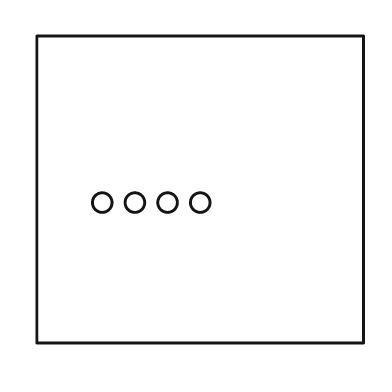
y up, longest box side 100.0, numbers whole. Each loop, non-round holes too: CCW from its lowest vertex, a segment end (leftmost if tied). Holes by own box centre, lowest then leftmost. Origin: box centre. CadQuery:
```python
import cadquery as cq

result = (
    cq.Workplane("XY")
    .moveTo(-50.0, -47.0)
    .lineTo(50.0, -47.0)
    .lineTo(50.0, 47.0)
    .lineTo(-50.0, 47.0)
    .close()
    .moveTo(-30.0, -4.0)
    .circle(3.0)
    .moveTo(-20.0, -4.0)
    .circle(3.0)
    .moveTo(-10.0, -4.0)
    .circle(3.0)
    .moveTo(0.0, -4.0)
    .circle(3.0)
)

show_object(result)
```